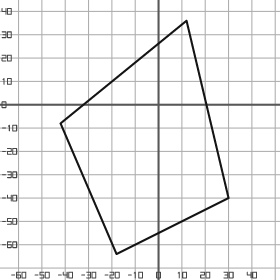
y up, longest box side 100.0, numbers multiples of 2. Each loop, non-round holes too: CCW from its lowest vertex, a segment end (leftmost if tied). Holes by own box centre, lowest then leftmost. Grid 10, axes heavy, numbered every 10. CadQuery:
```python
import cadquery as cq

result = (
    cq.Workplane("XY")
    .moveTo(-18.0, -64.0)
    .lineTo(30.0, -40.0)
    .lineTo(12.0, 36.0)
    .lineTo(-42.0, -8.0)
    .close()
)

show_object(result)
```